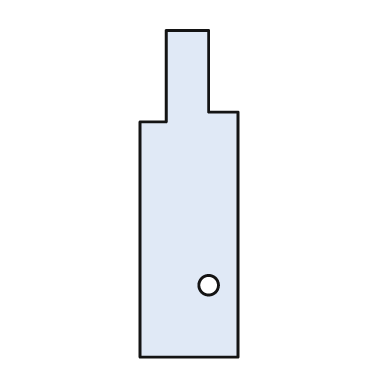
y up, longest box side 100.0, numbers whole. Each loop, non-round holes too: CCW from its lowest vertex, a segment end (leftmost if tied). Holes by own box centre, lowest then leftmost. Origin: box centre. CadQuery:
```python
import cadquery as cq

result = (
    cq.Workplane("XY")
    .moveTo(-15.0, -50.0)
    .lineTo(15.0, -50.0)
    .lineTo(15.0, 25.0)
    .lineTo(6.0, 25.0)
    .lineTo(6.0, 50.0)
    .lineTo(-7.0, 50.0)
    .lineTo(-7.0, 22.0)
    .lineTo(-15.0, 22.0)
    .close()
    .moveTo(6.0, -28.0)
    .circle(3.0)
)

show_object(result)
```